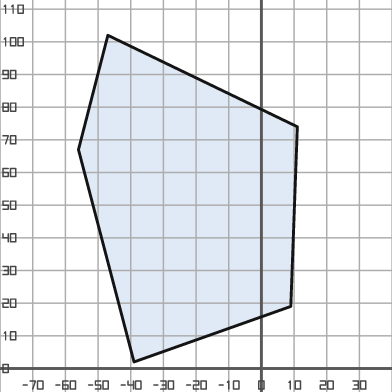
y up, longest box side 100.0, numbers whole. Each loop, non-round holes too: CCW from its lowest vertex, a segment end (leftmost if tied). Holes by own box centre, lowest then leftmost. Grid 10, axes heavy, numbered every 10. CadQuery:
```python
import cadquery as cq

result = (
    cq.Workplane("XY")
    .moveTo(-39.0, 2.0)
    .lineTo(9.0, 19.0)
    .lineTo(11.0, 74.0)
    .lineTo(-47.0, 102.0)
    .lineTo(-56.0, 67.0)
    .close()
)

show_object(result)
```